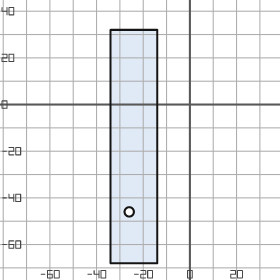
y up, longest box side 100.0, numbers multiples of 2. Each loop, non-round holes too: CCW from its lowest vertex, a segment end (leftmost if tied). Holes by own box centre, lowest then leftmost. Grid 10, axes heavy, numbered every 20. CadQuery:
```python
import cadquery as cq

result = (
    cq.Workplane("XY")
    .moveTo(-34.0, -68.0)
    .lineTo(-14.0, -68.0)
    .lineTo(-14.0, 32.0)
    .lineTo(-34.0, 32.0)
    .close()
    .moveTo(-26.0, -46.0)
    .circle(2.0)
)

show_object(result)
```